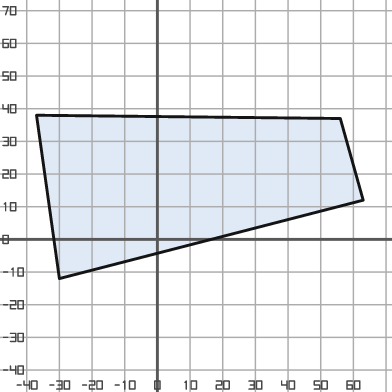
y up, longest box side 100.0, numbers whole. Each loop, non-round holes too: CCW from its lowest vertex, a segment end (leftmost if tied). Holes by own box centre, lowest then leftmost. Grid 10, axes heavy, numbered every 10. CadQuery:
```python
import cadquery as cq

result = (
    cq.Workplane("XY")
    .moveTo(-30.0, -12.0)
    .lineTo(63.0, 12.0)
    .lineTo(56.0, 37.0)
    .lineTo(-37.0, 38.0)
    .close()
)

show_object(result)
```